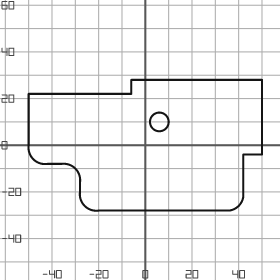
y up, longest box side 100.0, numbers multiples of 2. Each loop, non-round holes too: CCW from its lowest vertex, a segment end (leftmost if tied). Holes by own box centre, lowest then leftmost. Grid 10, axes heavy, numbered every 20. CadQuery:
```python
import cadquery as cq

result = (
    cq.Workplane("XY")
    .moveTo(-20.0, -28.0)
    .lineTo(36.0, -28.0)
    .threePointArc((40.0, -26.0), (42.0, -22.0))
    .lineTo(42.0, -4.0)
    .lineTo(50.0, -4.0)
    .lineTo(50.0, 28.0)
    .lineTo(-6.0, 28.0)
    .lineTo(-6.0, 22.0)
    .lineTo(-50.0, 22.0)
    .lineTo(-50.0, 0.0)
    .threePointArc((-48.0, -6.0), (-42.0, -8.0))
    .lineTo(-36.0, -8.0)
    .threePointArc((-30.0, -10.0), (-28.0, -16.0))
    .lineTo(-28.0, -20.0)
    .threePointArc((-26.0, -26.0), (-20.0, -28.0))
    .close()
    .moveTo(6.0, 10.0)
    .circle(4.0)
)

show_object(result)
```